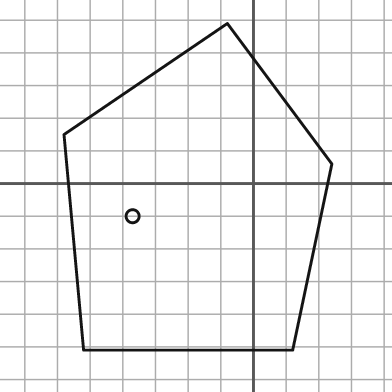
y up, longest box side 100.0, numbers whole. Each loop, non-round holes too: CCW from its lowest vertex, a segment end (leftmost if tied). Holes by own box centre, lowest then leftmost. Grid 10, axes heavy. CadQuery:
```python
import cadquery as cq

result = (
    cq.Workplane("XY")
    .moveTo(-52.0, -51.0)
    .lineTo(12.0, -51.0)
    .lineTo(24.0, 6.0)
    .lineTo(-8.0, 49.0)
    .lineTo(-58.0, 15.0)
    .close()
    .moveTo(-37.0, -10.0)
    .circle(2.0)
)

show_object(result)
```